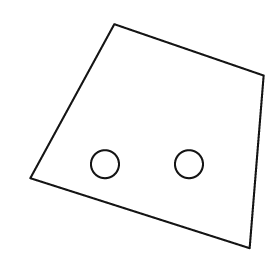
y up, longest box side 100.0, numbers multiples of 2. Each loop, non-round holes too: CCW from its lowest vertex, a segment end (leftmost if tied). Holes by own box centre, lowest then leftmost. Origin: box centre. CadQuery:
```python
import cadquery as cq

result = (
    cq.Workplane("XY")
    .moveTo(44.0, -48.0)
    .lineTo(50.0, 26.0)
    .lineTo(-14.0, 48.0)
    .lineTo(-50.0, -18.0)
    .close()
    .moveTo(-18.0, -12.0)
    .circle(6.0)
    .moveTo(18.0, -12.0)
    .circle(6.0)
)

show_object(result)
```